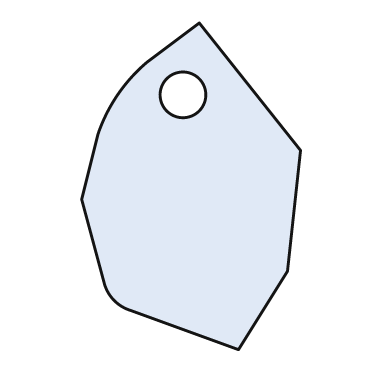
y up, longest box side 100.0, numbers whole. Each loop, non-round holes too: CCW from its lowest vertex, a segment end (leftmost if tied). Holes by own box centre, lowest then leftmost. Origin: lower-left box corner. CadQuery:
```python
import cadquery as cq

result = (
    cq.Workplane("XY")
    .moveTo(48.0, 0.0)
    .lineTo(63.0, 24.0)
    .lineTo(67.0, 61.0)
    .lineTo(36.0, 100.0)
    .lineTo(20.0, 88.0)
    .threePointArc((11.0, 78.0), (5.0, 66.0))
    .lineTo(0.0, 46.0)
    .lineTo(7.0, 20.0)
    .threePointArc((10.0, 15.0), (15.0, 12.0))
    .close()
    .moveTo(31.0, 78.0)
    .circle(7.0)
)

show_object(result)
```